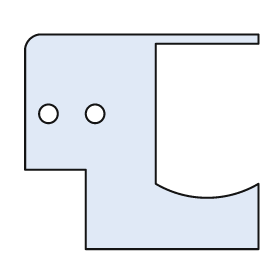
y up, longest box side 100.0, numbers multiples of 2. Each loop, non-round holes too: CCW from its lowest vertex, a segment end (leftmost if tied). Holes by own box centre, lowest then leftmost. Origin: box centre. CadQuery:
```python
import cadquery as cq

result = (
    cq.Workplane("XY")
    .moveTo(-24.0, -46.0)
    .lineTo(50.0, -46.0)
    .lineTo(50.0, -18.0)
    .threePointArc((28.0, -24.0), (6.0, -18.0))
    .lineTo(6.0, 42.0)
    .lineTo(50.0, 42.0)
    .lineTo(50.0, 46.0)
    .lineTo(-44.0, 46.0)
    .threePointArc((-48.0, 44.0), (-50.0, 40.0))
    .lineTo(-50.0, -12.0)
    .lineTo(-24.0, -12.0)
    .close()
    .moveTo(-40.0, 12.0)
    .circle(4.0)
    .moveTo(-20.0, 12.0)
    .circle(4.0)
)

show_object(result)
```